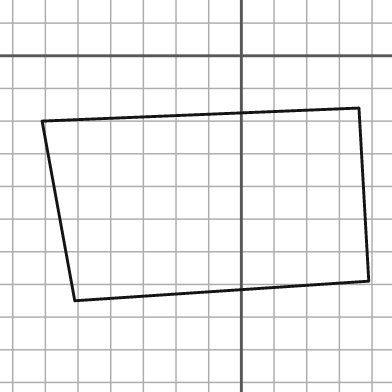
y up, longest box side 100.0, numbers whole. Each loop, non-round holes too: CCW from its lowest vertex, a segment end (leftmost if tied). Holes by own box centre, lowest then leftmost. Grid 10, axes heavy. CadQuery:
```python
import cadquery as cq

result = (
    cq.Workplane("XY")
    .moveTo(-51.0, -75.0)
    .lineTo(39.0, -69.0)
    .lineTo(36.0, -16.0)
    .lineTo(-61.0, -20.0)
    .close()
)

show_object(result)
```